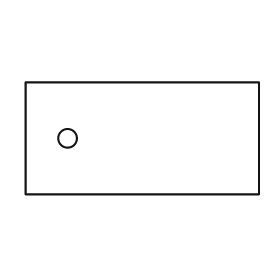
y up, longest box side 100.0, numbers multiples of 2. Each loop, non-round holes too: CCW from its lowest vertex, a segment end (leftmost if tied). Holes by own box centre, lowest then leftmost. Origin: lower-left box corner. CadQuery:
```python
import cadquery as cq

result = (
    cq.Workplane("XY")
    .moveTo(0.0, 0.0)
    .lineTo(100.0, 0.0)
    .lineTo(100.0, 48.0)
    .lineTo(0.0, 48.0)
    .close()
    .moveTo(18.0, 24.0)
    .circle(4.0)
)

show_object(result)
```